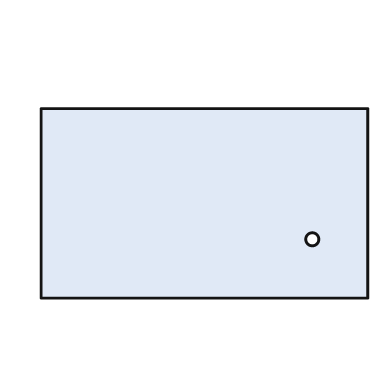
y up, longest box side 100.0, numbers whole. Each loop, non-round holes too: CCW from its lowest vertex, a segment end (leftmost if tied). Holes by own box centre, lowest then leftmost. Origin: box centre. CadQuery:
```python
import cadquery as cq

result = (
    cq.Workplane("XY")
    .moveTo(-50.0, -29.0)
    .lineTo(50.0, -29.0)
    .lineTo(50.0, 29.0)
    .lineTo(-50.0, 29.0)
    .close()
    .moveTo(33.0, -11.0)
    .circle(2.0)
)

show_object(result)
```